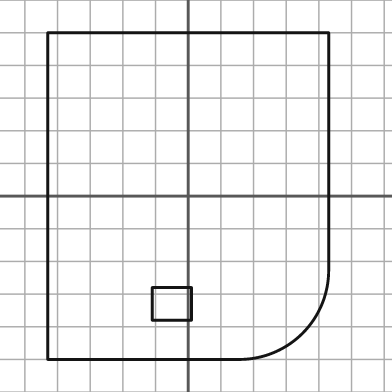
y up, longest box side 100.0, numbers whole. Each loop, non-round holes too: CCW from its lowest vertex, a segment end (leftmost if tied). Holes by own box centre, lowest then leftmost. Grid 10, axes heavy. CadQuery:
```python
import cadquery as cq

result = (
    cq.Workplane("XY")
    .moveTo(-43.0, -50.0)
    .lineTo(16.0, -50.0)
    .threePointArc((35.0, -42.0), (43.0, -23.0))
    .lineTo(43.0, 50.0)
    .lineTo(-43.0, 50.0)
    .close()
    .moveTo(-11.0, -38.0)
    .lineTo(1.0, -38.0)
    .lineTo(1.0, -28.0)
    .lineTo(-11.0, -28.0)
    .close()
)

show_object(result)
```